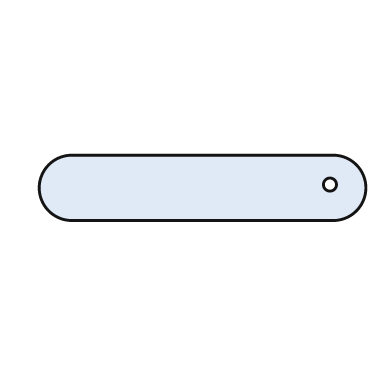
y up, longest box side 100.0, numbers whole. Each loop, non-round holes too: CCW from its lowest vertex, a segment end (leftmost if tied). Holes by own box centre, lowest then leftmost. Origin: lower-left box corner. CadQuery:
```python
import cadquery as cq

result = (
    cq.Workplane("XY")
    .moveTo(10.0, 0.0)
    .lineTo(90.0, 0.0)
    .threePointArc((100.0, 10.0), (90.0, 20.0))
    .lineTo(10.0, 20.0)
    .threePointArc((0.0, 10.0), (10.0, 0.0))
    .close()
    .moveTo(89.0, 11.0)
    .circle(2.0)
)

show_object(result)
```